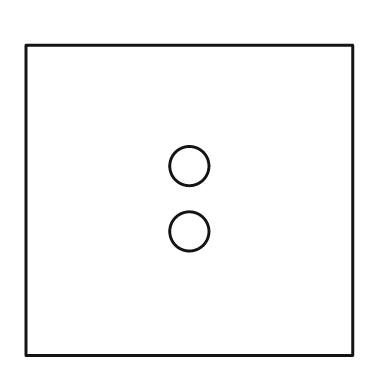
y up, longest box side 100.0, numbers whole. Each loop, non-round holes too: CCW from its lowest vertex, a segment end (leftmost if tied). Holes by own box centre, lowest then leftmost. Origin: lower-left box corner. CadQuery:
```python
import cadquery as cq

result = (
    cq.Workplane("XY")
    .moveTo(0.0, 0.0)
    .lineTo(100.0, 0.0)
    .lineTo(100.0, 95.0)
    .lineTo(0.0, 95.0)
    .close()
    .moveTo(50.0, 38.0)
    .circle(6.0)
    .moveTo(50.0, 58.0)
    .circle(6.0)
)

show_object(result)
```